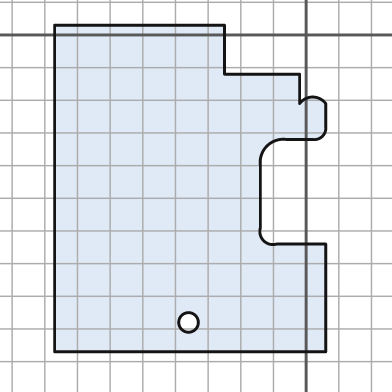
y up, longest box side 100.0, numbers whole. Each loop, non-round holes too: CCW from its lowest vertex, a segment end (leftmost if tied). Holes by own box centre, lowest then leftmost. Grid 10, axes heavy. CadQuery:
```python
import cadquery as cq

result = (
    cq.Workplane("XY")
    .moveTo(-77.0, -97.0)
    .lineTo(6.0, -97.0)
    .lineTo(6.0, -64.0)
    .lineTo(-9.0, -64.0)
    .threePointArc((-13.0, -63.0), (-14.0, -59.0))
    .lineTo(-14.0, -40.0)
    .threePointArc((-12.0, -34.0), (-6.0, -32.0))
    .lineTo(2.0, -32.0)
    .threePointArc((5.0, -31.0), (6.0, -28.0))
    .lineTo(6.0, -21.0)
    .threePointArc((2.0, -19.0), (-2.0, -21.0))
    .lineTo(-2.0, -12.0)
    .lineTo(-25.0, -12.0)
    .lineTo(-25.0, 3.0)
    .lineTo(-77.0, 3.0)
    .close()
    .moveTo(-36.0, -88.0)
    .circle(3.0)
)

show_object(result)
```